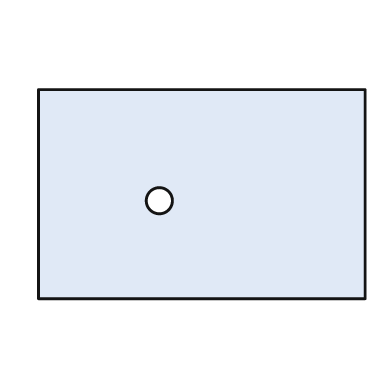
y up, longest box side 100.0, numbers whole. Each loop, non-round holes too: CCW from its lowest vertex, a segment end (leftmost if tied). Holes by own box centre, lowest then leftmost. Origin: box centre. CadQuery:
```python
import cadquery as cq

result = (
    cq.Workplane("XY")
    .moveTo(-50.0, -32.0)
    .lineTo(50.0, -32.0)
    .lineTo(50.0, 32.0)
    .lineTo(-50.0, 32.0)
    .close()
    .moveTo(-13.0, -2.0)
    .circle(4.0)
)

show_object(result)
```